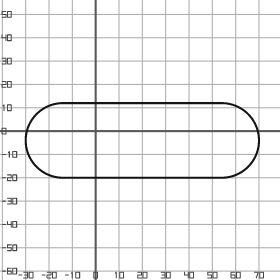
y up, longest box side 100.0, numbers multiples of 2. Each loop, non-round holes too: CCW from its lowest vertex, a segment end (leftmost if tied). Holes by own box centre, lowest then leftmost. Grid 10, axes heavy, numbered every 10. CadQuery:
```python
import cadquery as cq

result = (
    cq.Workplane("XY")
    .moveTo(-14.0, -20.0)
    .lineTo(54.0, -20.0)
    .threePointArc((70.0, -4.0), (54.0, 12.0))
    .lineTo(-14.0, 12.0)
    .threePointArc((-30.0, -4.0), (-14.0, -20.0))
    .close()
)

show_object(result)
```